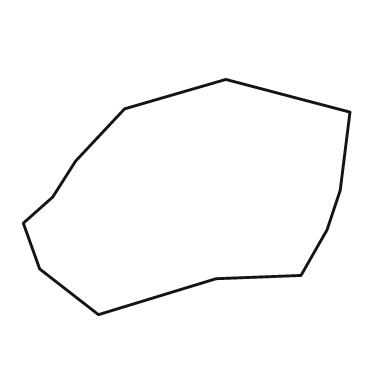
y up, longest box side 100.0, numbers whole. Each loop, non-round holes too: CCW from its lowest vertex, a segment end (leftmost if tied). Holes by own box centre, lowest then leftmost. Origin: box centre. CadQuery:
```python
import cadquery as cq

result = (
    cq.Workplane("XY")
    .moveTo(-27.0, -36.0)
    .lineTo(9.0, -25.0)
    .lineTo(35.0, -24.0)
    .lineTo(43.0, -10.0)
    .lineTo(47.0, 2.0)
    .lineTo(50.0, 26.0)
    .lineTo(12.0, 36.0)
    .lineTo(-19.0, 27.0)
    .lineTo(-34.0, 11.0)
    .lineTo(-41.0, 0.0)
    .lineTo(-50.0, -8.0)
    .lineTo(-45.0, -22.0)
    .close()
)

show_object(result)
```